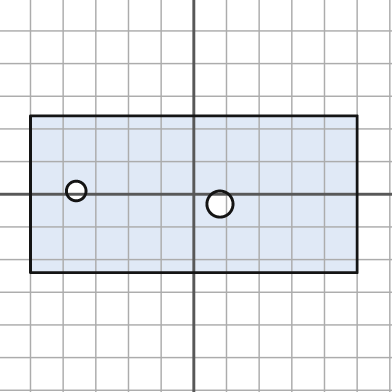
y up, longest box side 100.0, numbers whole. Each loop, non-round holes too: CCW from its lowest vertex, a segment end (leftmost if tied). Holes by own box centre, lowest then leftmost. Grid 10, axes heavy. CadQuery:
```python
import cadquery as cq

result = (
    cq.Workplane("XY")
    .moveTo(-50.0, -24.0)
    .lineTo(50.0, -24.0)
    .lineTo(50.0, 24.0)
    .lineTo(-50.0, 24.0)
    .close()
    .moveTo(8.0, -3.0)
    .circle(4.0)
    .moveTo(-36.0, 1.0)
    .circle(3.0)
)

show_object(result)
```